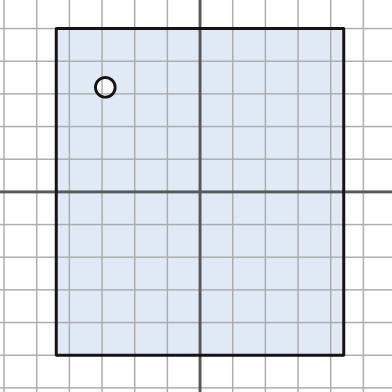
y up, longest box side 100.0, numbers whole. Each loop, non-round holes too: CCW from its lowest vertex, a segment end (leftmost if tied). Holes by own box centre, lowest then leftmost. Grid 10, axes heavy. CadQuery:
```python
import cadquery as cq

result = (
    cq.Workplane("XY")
    .moveTo(-44.0, -50.0)
    .lineTo(44.0, -50.0)
    .lineTo(44.0, 50.0)
    .lineTo(-44.0, 50.0)
    .close()
    .moveTo(-29.0, 32.0)
    .circle(3.0)
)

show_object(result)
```